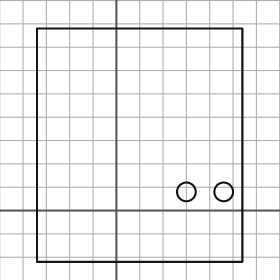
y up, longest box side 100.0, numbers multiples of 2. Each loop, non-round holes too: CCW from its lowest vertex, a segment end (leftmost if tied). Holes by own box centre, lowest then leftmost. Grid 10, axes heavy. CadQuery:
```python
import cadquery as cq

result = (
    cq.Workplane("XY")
    .moveTo(-34.0, -22.0)
    .lineTo(54.0, -22.0)
    .lineTo(54.0, 78.0)
    .lineTo(-34.0, 78.0)
    .close()
    .moveTo(30.0, 8.0)
    .circle(4.0)
    .moveTo(46.0, 8.0)
    .circle(4.0)
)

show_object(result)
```